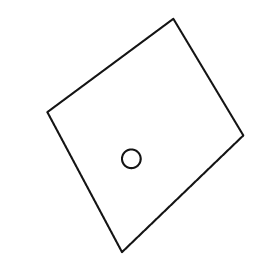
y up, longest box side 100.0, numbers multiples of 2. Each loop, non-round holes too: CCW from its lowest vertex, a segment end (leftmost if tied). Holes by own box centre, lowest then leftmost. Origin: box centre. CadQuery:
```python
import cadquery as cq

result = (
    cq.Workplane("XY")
    .moveTo(-10.0, -50.0)
    .lineTo(42.0, 0.0)
    .lineTo(12.0, 50.0)
    .lineTo(-42.0, 10.0)
    .close()
    .moveTo(-6.0, -10.0)
    .circle(4.0)
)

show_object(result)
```